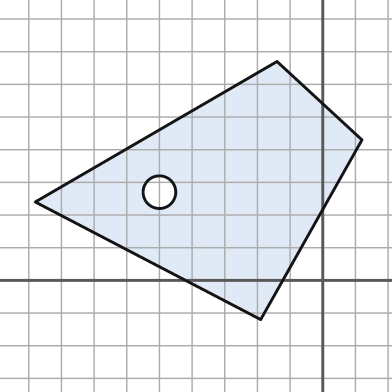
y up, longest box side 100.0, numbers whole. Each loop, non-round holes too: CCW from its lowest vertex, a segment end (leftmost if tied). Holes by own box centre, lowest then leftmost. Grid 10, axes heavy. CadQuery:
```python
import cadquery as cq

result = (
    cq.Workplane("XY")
    .moveTo(-19.0, -12.0)
    .lineTo(12.0, 43.0)
    .lineTo(-14.0, 67.0)
    .lineTo(-88.0, 24.0)
    .close()
    .moveTo(-50.0, 27.0)
    .circle(5.0)
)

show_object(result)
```